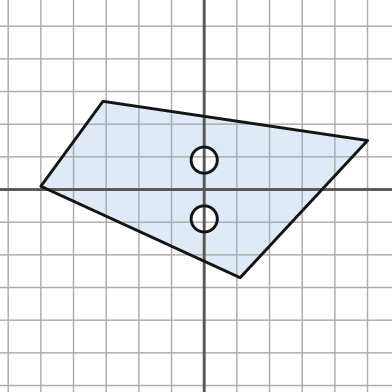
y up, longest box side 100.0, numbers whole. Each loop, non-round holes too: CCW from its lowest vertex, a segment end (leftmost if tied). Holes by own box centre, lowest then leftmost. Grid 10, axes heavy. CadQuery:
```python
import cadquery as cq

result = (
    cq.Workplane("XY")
    .moveTo(11.0, -27.0)
    .lineTo(50.0, 15.0)
    .lineTo(-31.0, 27.0)
    .lineTo(-50.0, 1.0)
    .close()
    .moveTo(0.0, -9.0)
    .circle(4.0)
    .moveTo(0.0, 9.0)
    .circle(4.0)
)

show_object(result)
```